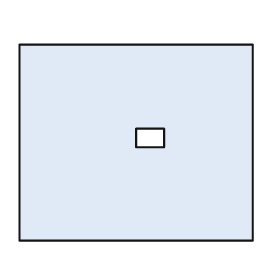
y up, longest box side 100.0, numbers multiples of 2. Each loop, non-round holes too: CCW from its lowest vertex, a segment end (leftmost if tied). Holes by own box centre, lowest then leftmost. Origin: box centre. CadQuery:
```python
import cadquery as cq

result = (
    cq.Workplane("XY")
    .moveTo(-50.0, -42.0)
    .lineTo(50.0, -42.0)
    .lineTo(50.0, 42.0)
    .lineTo(-50.0, 42.0)
    .close()
    .moveTo(0.0, -2.0)
    .lineTo(12.0, -2.0)
    .lineTo(12.0, 6.0)
    .lineTo(0.0, 6.0)
    .close()
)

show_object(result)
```